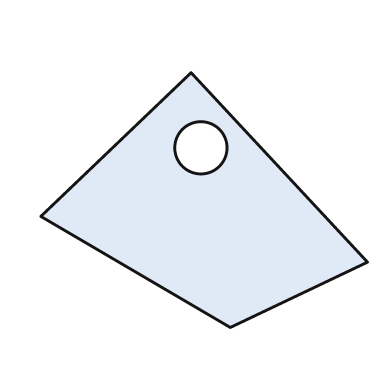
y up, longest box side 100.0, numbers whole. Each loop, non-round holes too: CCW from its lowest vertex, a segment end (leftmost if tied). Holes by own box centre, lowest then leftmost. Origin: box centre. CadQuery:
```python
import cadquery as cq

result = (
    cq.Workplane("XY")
    .moveTo(8.0, -39.0)
    .lineTo(50.0, -19.0)
    .lineTo(-4.0, 39.0)
    .lineTo(-50.0, -5.0)
    .close()
    .moveTo(-1.0, 16.0)
    .circle(8.0)
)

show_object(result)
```